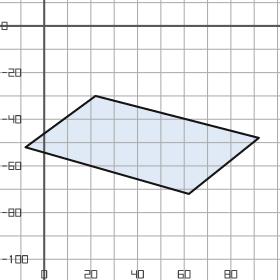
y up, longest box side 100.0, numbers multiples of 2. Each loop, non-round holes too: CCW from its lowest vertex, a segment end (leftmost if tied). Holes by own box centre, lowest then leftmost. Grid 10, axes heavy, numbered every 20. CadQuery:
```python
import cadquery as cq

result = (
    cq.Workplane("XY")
    .moveTo(62.0, -72.0)
    .lineTo(92.0, -48.0)
    .lineTo(22.0, -30.0)
    .lineTo(-8.0, -52.0)
    .close()
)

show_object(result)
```